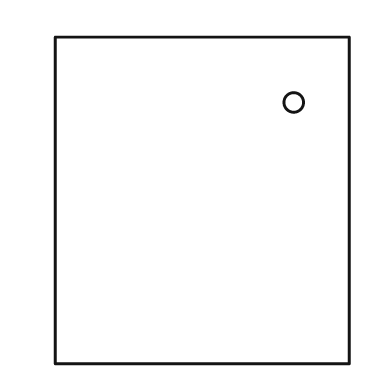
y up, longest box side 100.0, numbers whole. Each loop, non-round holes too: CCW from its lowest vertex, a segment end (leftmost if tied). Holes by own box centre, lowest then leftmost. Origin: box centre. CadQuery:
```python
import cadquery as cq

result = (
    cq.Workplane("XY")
    .moveTo(-45.0, -50.0)
    .lineTo(45.0, -50.0)
    .lineTo(45.0, 50.0)
    .lineTo(-45.0, 50.0)
    .close()
    .moveTo(28.0, 30.0)
    .circle(3.0)
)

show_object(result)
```